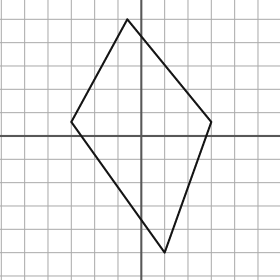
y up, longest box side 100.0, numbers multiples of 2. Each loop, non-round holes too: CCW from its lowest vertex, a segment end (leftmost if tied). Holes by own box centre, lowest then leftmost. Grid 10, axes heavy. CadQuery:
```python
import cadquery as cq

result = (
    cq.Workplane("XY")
    .moveTo(10.0, -50.0)
    .lineTo(30.0, 6.0)
    .lineTo(-6.0, 50.0)
    .lineTo(-30.0, 6.0)
    .close()
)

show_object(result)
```